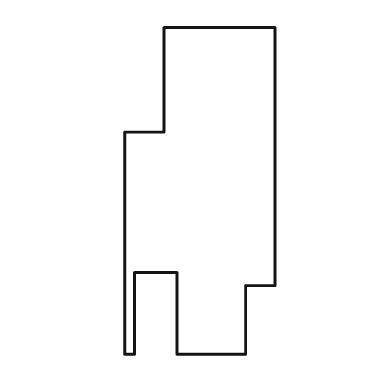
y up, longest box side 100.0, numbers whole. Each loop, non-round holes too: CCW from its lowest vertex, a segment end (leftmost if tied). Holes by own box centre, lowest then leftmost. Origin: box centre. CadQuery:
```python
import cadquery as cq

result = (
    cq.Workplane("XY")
    .moveTo(-23.0, -50.0)
    .lineTo(-20.0, -50.0)
    .lineTo(-20.0, -25.0)
    .lineTo(-7.0, -25.0)
    .lineTo(-7.0, -50.0)
    .lineTo(14.0, -50.0)
    .lineTo(14.0, -29.0)
    .lineTo(23.0, -29.0)
    .lineTo(23.0, 50.0)
    .lineTo(-11.0, 50.0)
    .lineTo(-11.0, 18.0)
    .lineTo(-23.0, 18.0)
    .close()
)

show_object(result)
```